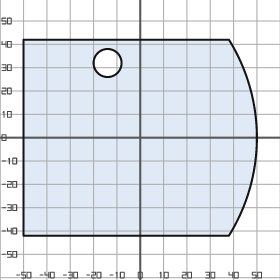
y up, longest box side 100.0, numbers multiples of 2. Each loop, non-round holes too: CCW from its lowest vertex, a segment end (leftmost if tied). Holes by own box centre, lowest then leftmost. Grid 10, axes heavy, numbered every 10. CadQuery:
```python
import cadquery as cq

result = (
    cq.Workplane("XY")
    .moveTo(-50.0, -42.0)
    .lineTo(38.0, -42.0)
    .threePointArc((50.0, 0.0), (38.0, 42.0))
    .lineTo(-50.0, 42.0)
    .close()
    .moveTo(-14.0, 32.0)
    .circle(6.0)
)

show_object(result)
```